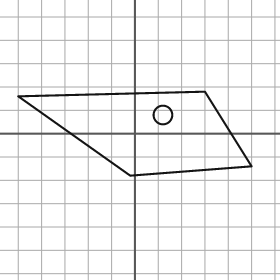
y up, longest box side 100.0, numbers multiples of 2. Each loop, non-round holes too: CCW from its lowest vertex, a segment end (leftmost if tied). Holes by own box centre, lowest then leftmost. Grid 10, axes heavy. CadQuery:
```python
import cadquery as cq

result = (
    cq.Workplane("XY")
    .moveTo(-2.0, -18.0)
    .lineTo(50.0, -14.0)
    .lineTo(30.0, 18.0)
    .lineTo(-50.0, 16.0)
    .close()
    .moveTo(12.0, 8.0)
    .circle(4.0)
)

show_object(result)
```